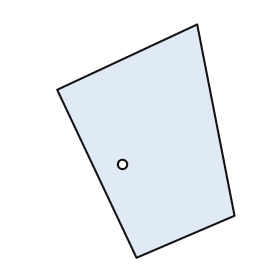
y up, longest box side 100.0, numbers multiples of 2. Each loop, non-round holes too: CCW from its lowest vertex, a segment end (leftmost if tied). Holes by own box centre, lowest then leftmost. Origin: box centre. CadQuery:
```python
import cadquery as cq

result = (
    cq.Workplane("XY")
    .moveTo(-4.0, -50.0)
    .lineTo(38.0, -32.0)
    .lineTo(22.0, 50.0)
    .lineTo(-38.0, 22.0)
    .close()
    .moveTo(-10.0, -10.0)
    .circle(2.0)
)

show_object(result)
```